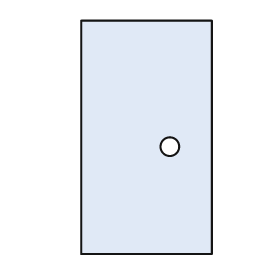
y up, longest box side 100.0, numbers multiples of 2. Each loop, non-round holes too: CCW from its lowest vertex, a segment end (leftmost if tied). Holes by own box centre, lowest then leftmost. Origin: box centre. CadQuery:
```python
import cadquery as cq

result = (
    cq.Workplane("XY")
    .moveTo(-28.0, -50.0)
    .lineTo(28.0, -50.0)
    .lineTo(28.0, 50.0)
    .lineTo(-28.0, 50.0)
    .close()
    .moveTo(10.0, -4.0)
    .circle(4.0)
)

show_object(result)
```